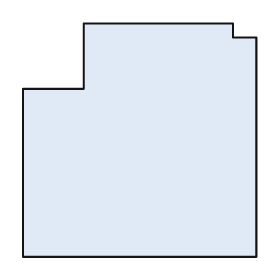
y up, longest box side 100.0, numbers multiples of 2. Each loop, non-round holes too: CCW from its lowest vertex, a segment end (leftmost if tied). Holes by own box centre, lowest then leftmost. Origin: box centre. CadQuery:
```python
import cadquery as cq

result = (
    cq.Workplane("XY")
    .moveTo(-50.0, -50.0)
    .lineTo(50.0, -50.0)
    .lineTo(50.0, 44.0)
    .lineTo(40.0, 44.0)
    .lineTo(40.0, 50.0)
    .lineTo(-24.0, 50.0)
    .lineTo(-24.0, 22.0)
    .lineTo(-50.0, 22.0)
    .close()
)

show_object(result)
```